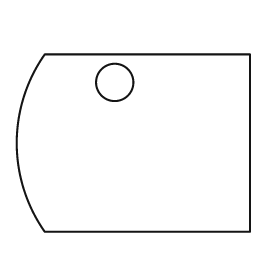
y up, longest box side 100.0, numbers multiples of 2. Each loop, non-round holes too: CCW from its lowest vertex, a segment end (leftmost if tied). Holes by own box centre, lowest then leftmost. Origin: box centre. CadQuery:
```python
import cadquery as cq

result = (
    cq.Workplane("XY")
    .moveTo(-38.0, -38.0)
    .lineTo(50.0, -38.0)
    .lineTo(50.0, 38.0)
    .lineTo(-38.0, 38.0)
    .threePointArc((-50.0, 0.0), (-38.0, -38.0))
    .close()
    .moveTo(-8.0, 26.0)
    .circle(8.0)
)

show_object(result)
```